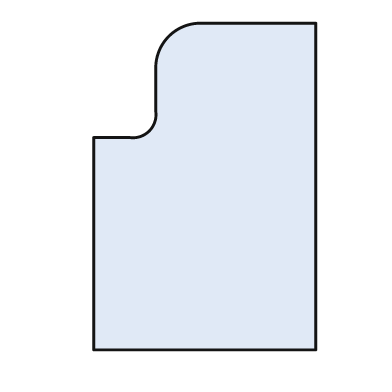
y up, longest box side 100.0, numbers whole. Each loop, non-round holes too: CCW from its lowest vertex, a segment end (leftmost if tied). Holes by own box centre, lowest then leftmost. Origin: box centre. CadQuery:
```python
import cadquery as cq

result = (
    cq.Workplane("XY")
    .moveTo(-34.0, -50.0)
    .lineTo(34.0, -50.0)
    .lineTo(34.0, 50.0)
    .lineTo(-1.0, 50.0)
    .threePointArc((-11.0, 46.0), (-15.0, 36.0))
    .lineTo(-15.0, 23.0)
    .threePointArc((-17.0, 17.0), (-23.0, 15.0))
    .lineTo(-34.0, 15.0)
    .close()
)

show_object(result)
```